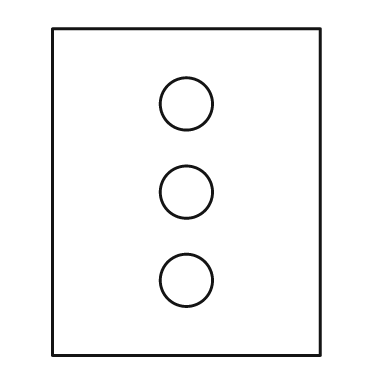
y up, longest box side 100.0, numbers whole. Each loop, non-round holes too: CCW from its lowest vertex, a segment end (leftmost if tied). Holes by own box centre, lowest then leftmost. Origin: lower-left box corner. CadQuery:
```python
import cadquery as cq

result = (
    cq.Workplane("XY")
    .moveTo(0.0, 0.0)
    .lineTo(82.0, 0.0)
    .lineTo(82.0, 100.0)
    .lineTo(0.0, 100.0)
    .close()
    .moveTo(41.0, 23.0)
    .circle(8.0)
    .moveTo(41.0, 50.0)
    .circle(8.0)
    .moveTo(41.0, 77.0)
    .circle(8.0)
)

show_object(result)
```